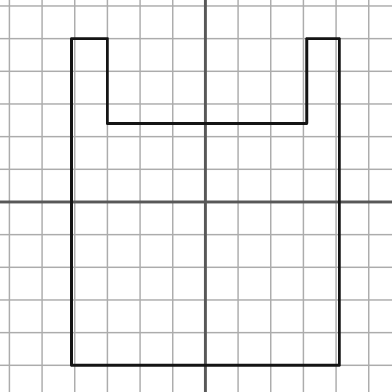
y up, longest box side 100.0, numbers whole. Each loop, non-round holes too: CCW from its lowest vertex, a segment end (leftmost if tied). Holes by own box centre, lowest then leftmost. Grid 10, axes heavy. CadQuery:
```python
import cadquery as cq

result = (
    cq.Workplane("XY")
    .moveTo(-41.0, -50.0)
    .lineTo(41.0, -50.0)
    .lineTo(41.0, 50.0)
    .lineTo(31.0, 50.0)
    .lineTo(31.0, 24.0)
    .lineTo(-30.0, 24.0)
    .lineTo(-30.0, 50.0)
    .lineTo(-41.0, 50.0)
    .close()
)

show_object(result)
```